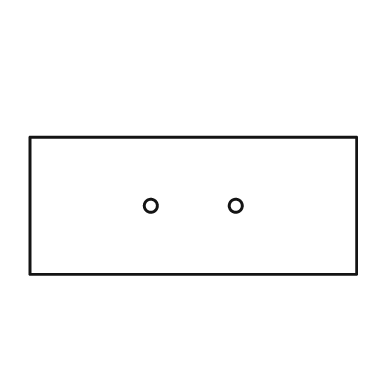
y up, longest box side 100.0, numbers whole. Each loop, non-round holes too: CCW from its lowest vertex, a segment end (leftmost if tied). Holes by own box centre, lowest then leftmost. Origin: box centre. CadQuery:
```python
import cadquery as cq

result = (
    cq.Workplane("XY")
    .moveTo(-50.0, -21.0)
    .lineTo(50.0, -21.0)
    .lineTo(50.0, 21.0)
    .lineTo(-50.0, 21.0)
    .close()
    .moveTo(-13.0, 0.0)
    .circle(2.0)
    .moveTo(13.0, 0.0)
    .circle(2.0)
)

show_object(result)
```